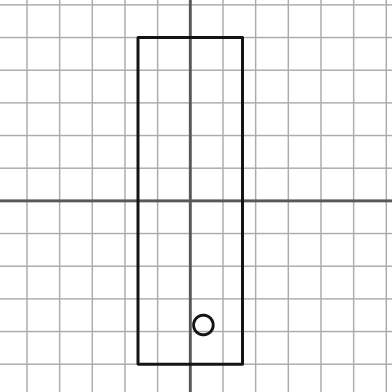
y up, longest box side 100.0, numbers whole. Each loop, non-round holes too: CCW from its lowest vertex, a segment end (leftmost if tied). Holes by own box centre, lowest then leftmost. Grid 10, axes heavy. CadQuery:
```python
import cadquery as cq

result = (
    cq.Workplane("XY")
    .moveTo(-16.0, -50.0)
    .lineTo(16.0, -50.0)
    .lineTo(16.0, 50.0)
    .lineTo(-16.0, 50.0)
    .close()
    .moveTo(4.0, -38.0)
    .circle(3.0)
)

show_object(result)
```